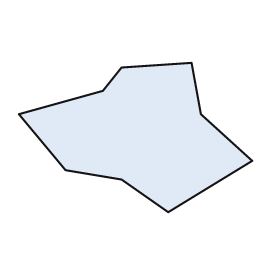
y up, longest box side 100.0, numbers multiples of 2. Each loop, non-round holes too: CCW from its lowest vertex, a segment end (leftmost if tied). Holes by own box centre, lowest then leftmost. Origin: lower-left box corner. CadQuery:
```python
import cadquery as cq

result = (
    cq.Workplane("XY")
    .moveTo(64.0, 0.0)
    .lineTo(100.0, 22.0)
    .lineTo(78.0, 42.0)
    .lineTo(74.0, 64.0)
    .lineTo(44.0, 62.0)
    .lineTo(36.0, 52.0)
    .lineTo(0.0, 42.0)
    .lineTo(20.0, 18.0)
    .lineTo(44.0, 14.0)
    .close()
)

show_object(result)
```